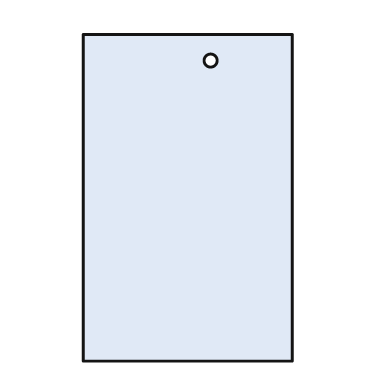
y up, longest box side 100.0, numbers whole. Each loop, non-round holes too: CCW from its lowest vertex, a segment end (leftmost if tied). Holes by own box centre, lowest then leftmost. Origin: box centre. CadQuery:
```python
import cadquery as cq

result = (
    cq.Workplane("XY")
    .moveTo(-32.0, -50.0)
    .lineTo(32.0, -50.0)
    .lineTo(32.0, 50.0)
    .lineTo(-32.0, 50.0)
    .close()
    .moveTo(7.0, 42.0)
    .circle(2.0)
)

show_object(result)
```